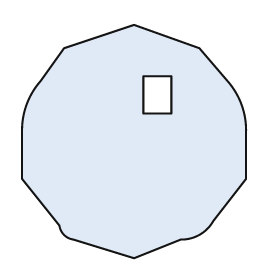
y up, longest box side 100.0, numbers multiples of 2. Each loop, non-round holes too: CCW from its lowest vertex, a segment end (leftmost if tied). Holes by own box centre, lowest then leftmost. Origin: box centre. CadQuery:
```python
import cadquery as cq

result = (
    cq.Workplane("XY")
    .moveTo(0.0, -50.0)
    .lineTo(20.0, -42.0)
    .threePointArc((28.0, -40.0), (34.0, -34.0))
    .lineTo(48.0, -16.0)
    .lineTo(48.0, 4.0)
    .threePointArc((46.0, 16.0), (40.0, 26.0))
    .lineTo(28.0, 40.0)
    .lineTo(0.0, 50.0)
    .lineTo(-30.0, 40.0)
    .lineTo(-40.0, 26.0)
    .threePointArc((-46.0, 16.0), (-48.0, 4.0))
    .lineTo(-48.0, -16.0)
    .lineTo(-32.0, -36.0)
    .threePointArc((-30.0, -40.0), (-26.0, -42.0))
    .close()
    .moveTo(4.0, 12.0)
    .lineTo(16.0, 12.0)
    .lineTo(16.0, 28.0)
    .lineTo(4.0, 28.0)
    .close()
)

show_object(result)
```